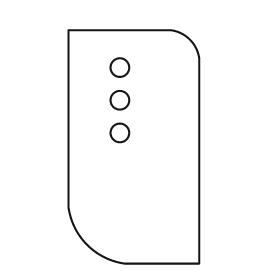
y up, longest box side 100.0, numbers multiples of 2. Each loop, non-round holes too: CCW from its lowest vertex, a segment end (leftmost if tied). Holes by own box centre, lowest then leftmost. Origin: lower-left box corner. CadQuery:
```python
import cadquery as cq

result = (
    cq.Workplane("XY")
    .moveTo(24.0, 0.0)
    .lineTo(56.0, 0.0)
    .lineTo(56.0, 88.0)
    .threePointArc((52.0, 96.0), (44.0, 100.0))
    .lineTo(0.0, 100.0)
    .lineTo(0.0, 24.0)
    .threePointArc((8.0, 8.0), (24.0, 0.0))
    .close()
    .moveTo(22.0, 56.0)
    .circle(4.0)
    .moveTo(22.0, 70.0)
    .circle(4.0)
    .moveTo(22.0, 84.0)
    .circle(4.0)
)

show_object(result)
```